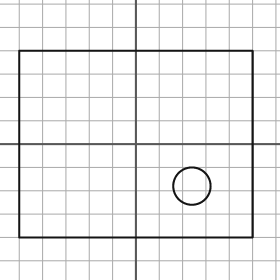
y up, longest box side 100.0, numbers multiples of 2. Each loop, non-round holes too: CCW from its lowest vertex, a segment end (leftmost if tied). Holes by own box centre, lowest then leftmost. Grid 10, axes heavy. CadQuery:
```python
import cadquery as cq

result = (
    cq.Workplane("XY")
    .moveTo(-50.0, -40.0)
    .lineTo(50.0, -40.0)
    .lineTo(50.0, 40.0)
    .lineTo(-50.0, 40.0)
    .close()
    .moveTo(24.0, -18.0)
    .circle(8.0)
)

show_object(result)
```